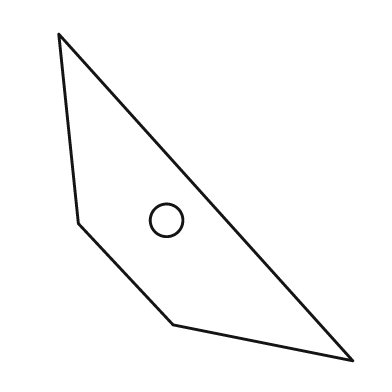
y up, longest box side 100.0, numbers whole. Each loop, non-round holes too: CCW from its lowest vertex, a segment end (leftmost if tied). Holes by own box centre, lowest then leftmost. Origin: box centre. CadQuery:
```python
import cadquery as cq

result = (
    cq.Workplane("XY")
    .moveTo(45.0, -50.0)
    .lineTo(-45.0, 50.0)
    .lineTo(-39.0, -8.0)
    .lineTo(-10.0, -39.0)
    .close()
    .moveTo(-12.0, -7.0)
    .circle(5.0)
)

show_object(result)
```